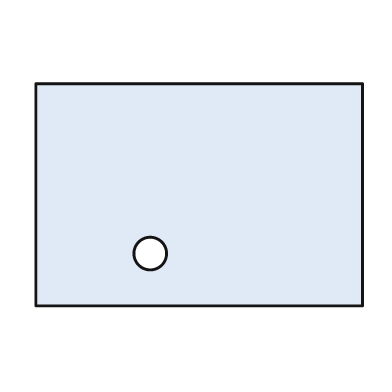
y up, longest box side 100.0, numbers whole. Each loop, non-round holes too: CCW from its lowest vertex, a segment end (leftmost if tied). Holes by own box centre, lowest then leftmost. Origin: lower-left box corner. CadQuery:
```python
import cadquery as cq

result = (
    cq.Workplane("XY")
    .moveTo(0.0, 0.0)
    .lineTo(100.0, 0.0)
    .lineTo(100.0, 68.0)
    .lineTo(0.0, 68.0)
    .close()
    .moveTo(35.0, 16.0)
    .circle(5.0)
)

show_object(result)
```